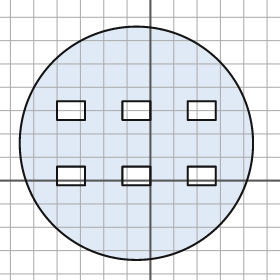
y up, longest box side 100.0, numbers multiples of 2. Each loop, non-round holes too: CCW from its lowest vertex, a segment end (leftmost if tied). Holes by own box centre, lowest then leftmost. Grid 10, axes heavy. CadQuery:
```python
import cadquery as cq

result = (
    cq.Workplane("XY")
    .moveTo(-6.0, 16.0)
    .circle(50.0)
    .moveTo(-40.0, -2.0)
    .lineTo(-28.0, -2.0)
    .lineTo(-28.0, 6.0)
    .lineTo(-40.0, 6.0)
    .close()
    .moveTo(-12.0, -2.0)
    .lineTo(0.0, -2.0)
    .lineTo(0.0, 6.0)
    .lineTo(-12.0, 6.0)
    .close()
    .moveTo(16.0, -2.0)
    .lineTo(28.0, -2.0)
    .lineTo(28.0, 6.0)
    .lineTo(16.0, 6.0)
    .close()
    .moveTo(-40.0, 26.0)
    .lineTo(-28.0, 26.0)
    .lineTo(-28.0, 34.0)
    .lineTo(-40.0, 34.0)
    .close()
    .moveTo(-12.0, 26.0)
    .lineTo(0.0, 26.0)
    .lineTo(0.0, 34.0)
    .lineTo(-12.0, 34.0)
    .close()
    .moveTo(16.0, 26.0)
    .lineTo(28.0, 26.0)
    .lineTo(28.0, 34.0)
    .lineTo(16.0, 34.0)
    .close()
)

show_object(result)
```